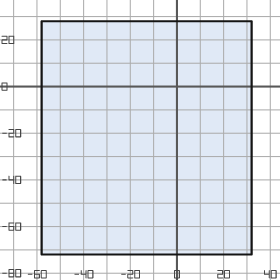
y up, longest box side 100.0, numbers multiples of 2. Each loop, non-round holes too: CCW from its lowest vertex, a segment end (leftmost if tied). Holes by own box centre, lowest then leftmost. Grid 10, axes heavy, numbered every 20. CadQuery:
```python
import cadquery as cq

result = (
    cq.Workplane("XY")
    .moveTo(-58.0, -72.0)
    .lineTo(32.0, -72.0)
    .lineTo(32.0, 28.0)
    .lineTo(-58.0, 28.0)
    .close()
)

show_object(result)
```